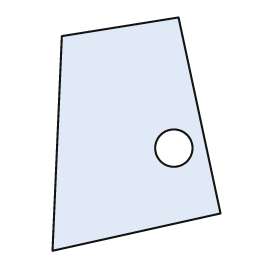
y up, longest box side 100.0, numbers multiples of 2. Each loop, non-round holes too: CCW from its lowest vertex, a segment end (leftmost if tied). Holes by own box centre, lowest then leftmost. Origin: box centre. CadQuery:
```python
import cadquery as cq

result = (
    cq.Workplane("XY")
    .moveTo(-36.0, -50.0)
    .lineTo(36.0, -34.0)
    .lineTo(18.0, 50.0)
    .lineTo(-32.0, 42.0)
    .close()
    .moveTo(16.0, -6.0)
    .circle(8.0)
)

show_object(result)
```